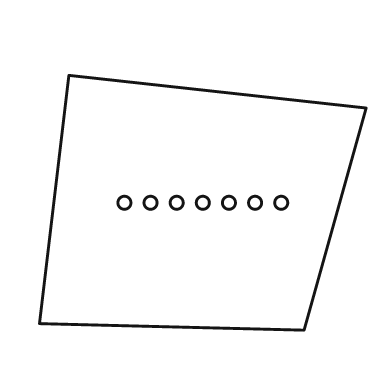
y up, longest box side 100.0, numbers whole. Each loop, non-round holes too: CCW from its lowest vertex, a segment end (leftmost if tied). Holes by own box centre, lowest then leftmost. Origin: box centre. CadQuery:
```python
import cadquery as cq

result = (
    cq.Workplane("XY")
    .moveTo(31.0, -39.0)
    .lineTo(50.0, 29.0)
    .lineTo(-41.0, 39.0)
    .lineTo(-50.0, -37.0)
    .close()
    .moveTo(-24.0, 0.0)
    .circle(2.0)
    .moveTo(-16.0, 0.0)
    .circle(2.0)
    .moveTo(-8.0, 0.0)
    .circle(2.0)
    .moveTo(0.0, 0.0)
    .circle(2.0)
    .moveTo(8.0, 0.0)
    .circle(2.0)
    .moveTo(16.0, 0.0)
    .circle(2.0)
    .moveTo(24.0, 0.0)
    .circle(2.0)
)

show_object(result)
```